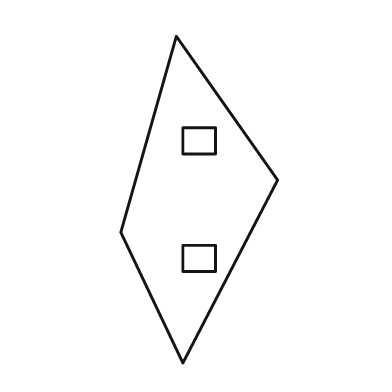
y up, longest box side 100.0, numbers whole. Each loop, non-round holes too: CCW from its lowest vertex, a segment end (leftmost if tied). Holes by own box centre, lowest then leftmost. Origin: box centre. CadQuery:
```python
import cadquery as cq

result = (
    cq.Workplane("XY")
    .moveTo(-5.0, -50.0)
    .lineTo(24.0, 6.0)
    .lineTo(-7.0, 50.0)
    .lineTo(-24.0, -10.0)
    .close()
    .moveTo(-5.0, -22.0)
    .lineTo(5.0, -22.0)
    .lineTo(5.0, -14.0)
    .lineTo(-5.0, -14.0)
    .close()
    .moveTo(-5.0, 14.0)
    .lineTo(5.0, 14.0)
    .lineTo(5.0, 22.0)
    .lineTo(-5.0, 22.0)
    .close()
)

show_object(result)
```